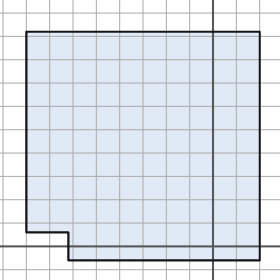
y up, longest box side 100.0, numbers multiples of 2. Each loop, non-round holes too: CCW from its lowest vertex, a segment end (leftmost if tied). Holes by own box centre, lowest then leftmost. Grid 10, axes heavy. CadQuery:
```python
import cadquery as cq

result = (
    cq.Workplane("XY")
    .moveTo(-62.0, -6.0)
    .lineTo(20.0, -6.0)
    .lineTo(20.0, 92.0)
    .lineTo(-80.0, 92.0)
    .lineTo(-80.0, 6.0)
    .lineTo(-62.0, 6.0)
    .close()
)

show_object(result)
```